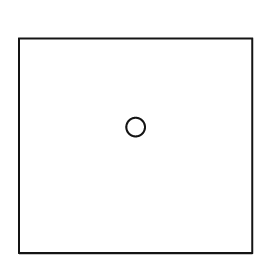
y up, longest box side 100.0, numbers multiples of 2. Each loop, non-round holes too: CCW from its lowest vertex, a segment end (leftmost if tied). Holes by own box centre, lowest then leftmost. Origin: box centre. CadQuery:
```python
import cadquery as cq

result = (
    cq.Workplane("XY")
    .moveTo(-50.0, -46.0)
    .lineTo(50.0, -46.0)
    .lineTo(50.0, 46.0)
    .lineTo(-50.0, 46.0)
    .close()
    .moveTo(0.0, 8.0)
    .circle(4.0)
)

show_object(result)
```